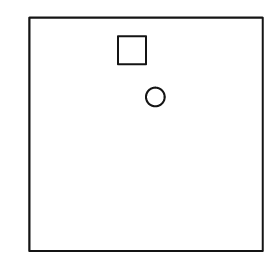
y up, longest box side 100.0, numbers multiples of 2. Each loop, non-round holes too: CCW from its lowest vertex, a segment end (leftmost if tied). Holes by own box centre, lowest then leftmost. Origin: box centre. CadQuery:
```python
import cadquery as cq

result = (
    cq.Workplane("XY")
    .moveTo(-50.0, -50.0)
    .lineTo(50.0, -50.0)
    .lineTo(50.0, 50.0)
    .lineTo(-50.0, 50.0)
    .close()
    .moveTo(4.0, 16.0)
    .circle(4.0)
    .moveTo(-12.0, 30.0)
    .lineTo(0.0, 30.0)
    .lineTo(0.0, 42.0)
    .lineTo(-12.0, 42.0)
    .close()
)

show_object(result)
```